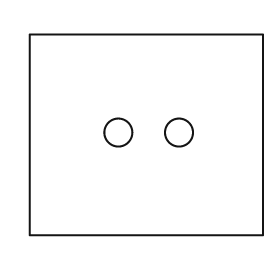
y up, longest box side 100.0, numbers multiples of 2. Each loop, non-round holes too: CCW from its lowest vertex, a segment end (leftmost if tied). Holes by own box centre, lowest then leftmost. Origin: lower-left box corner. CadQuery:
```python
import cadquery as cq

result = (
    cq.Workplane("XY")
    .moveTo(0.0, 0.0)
    .lineTo(100.0, 0.0)
    .lineTo(100.0, 86.0)
    .lineTo(0.0, 86.0)
    .close()
    .moveTo(38.0, 44.0)
    .circle(6.0)
    .moveTo(64.0, 44.0)
    .circle(6.0)
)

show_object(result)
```